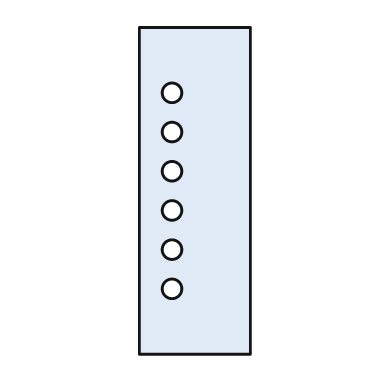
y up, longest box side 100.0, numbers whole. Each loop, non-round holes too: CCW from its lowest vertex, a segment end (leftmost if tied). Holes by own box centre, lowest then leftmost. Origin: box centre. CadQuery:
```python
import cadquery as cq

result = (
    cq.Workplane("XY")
    .moveTo(-17.0, -50.0)
    .lineTo(17.0, -50.0)
    .lineTo(17.0, 50.0)
    .lineTo(-17.0, 50.0)
    .close()
    .moveTo(-7.0, -30.0)
    .circle(3.0)
    .moveTo(-7.0, -18.0)
    .circle(3.0)
    .moveTo(-7.0, -6.0)
    .circle(3.0)
    .moveTo(-7.0, 6.0)
    .circle(3.0)
    .moveTo(-7.0, 18.0)
    .circle(3.0)
    .moveTo(-7.0, 30.0)
    .circle(3.0)
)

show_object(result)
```